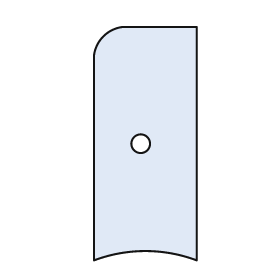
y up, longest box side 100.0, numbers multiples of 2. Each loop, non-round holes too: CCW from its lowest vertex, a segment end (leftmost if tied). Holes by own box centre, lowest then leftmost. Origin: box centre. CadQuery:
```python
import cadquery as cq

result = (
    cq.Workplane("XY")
    .moveTo(-22.0, -50.0)
    .threePointArc((0.0, -46.0), (22.0, -50.0))
    .lineTo(22.0, 50.0)
    .lineTo(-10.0, 50.0)
    .threePointArc((-18.0, 46.0), (-22.0, 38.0))
    .close()
    .moveTo(-2.0, 0.0)
    .circle(4.0)
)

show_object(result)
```